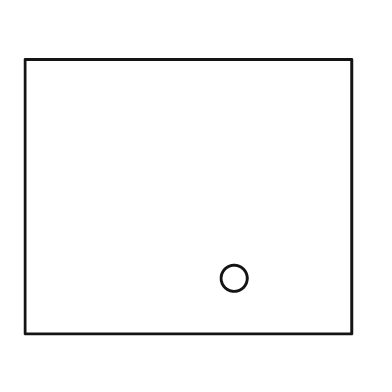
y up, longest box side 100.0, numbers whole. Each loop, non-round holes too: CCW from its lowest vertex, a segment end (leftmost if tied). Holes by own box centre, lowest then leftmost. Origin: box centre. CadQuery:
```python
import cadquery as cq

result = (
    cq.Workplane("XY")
    .moveTo(-50.0, -42.0)
    .lineTo(50.0, -42.0)
    .lineTo(50.0, 42.0)
    .lineTo(-50.0, 42.0)
    .close()
    .moveTo(14.0, -25.0)
    .circle(4.0)
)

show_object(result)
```